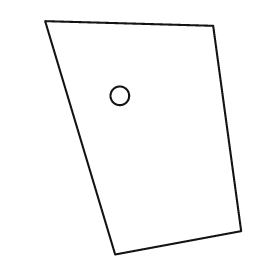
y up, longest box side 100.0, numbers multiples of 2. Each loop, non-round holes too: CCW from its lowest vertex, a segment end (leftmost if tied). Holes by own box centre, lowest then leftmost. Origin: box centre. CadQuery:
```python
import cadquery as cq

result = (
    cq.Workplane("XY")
    .moveTo(-12.0, -50.0)
    .lineTo(42.0, -40.0)
    .lineTo(30.0, 48.0)
    .lineTo(-42.0, 50.0)
    .close()
    .moveTo(-10.0, 18.0)
    .circle(4.0)
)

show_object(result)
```